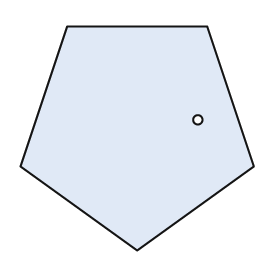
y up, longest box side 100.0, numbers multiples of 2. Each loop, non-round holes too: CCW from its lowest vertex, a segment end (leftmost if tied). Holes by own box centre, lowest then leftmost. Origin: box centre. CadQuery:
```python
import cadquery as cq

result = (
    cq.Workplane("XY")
    .moveTo(0.0, -48.0)
    .lineTo(50.0, -12.0)
    .lineTo(30.0, 48.0)
    .lineTo(-30.0, 48.0)
    .lineTo(-50.0, -12.0)
    .close()
    .moveTo(26.0, 8.0)
    .circle(2.0)
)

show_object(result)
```